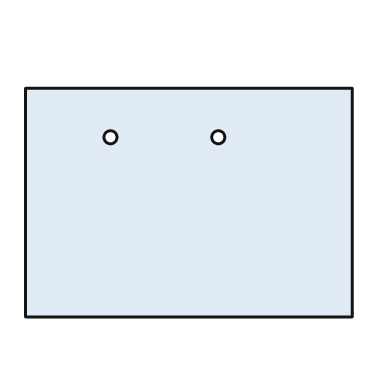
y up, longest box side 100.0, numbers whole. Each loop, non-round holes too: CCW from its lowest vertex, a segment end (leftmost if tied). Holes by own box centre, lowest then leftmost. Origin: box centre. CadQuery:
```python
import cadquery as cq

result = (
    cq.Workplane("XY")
    .moveTo(-50.0, -35.0)
    .lineTo(50.0, -35.0)
    .lineTo(50.0, 35.0)
    .lineTo(-50.0, 35.0)
    .close()
    .moveTo(-24.0, 20.0)
    .circle(2.0)
    .moveTo(9.0, 20.0)
    .circle(2.0)
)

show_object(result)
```